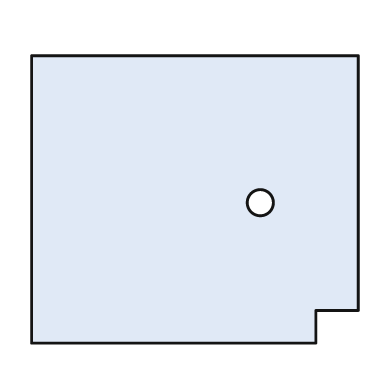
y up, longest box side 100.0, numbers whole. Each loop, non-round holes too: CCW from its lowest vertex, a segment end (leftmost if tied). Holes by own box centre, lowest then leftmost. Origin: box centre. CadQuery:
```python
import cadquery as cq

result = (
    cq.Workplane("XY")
    .moveTo(-50.0, -44.0)
    .lineTo(37.0, -44.0)
    .lineTo(37.0, -34.0)
    .lineTo(50.0, -34.0)
    .lineTo(50.0, 44.0)
    .lineTo(-50.0, 44.0)
    .close()
    .moveTo(20.0, -1.0)
    .circle(4.0)
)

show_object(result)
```